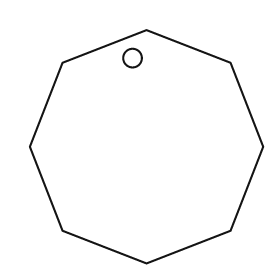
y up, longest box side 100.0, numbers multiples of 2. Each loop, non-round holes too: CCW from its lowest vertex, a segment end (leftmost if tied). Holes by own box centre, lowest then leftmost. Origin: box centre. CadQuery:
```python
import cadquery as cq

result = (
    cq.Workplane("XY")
    .moveTo(0.0, -50.0)
    .lineTo(36.0, -36.0)
    .lineTo(50.0, 0.0)
    .lineTo(36.0, 36.0)
    .lineTo(0.0, 50.0)
    .lineTo(-36.0, 36.0)
    .lineTo(-50.0, 0.0)
    .lineTo(-36.0, -36.0)
    .close()
    .moveTo(-6.0, 38.0)
    .circle(4.0)
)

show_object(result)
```